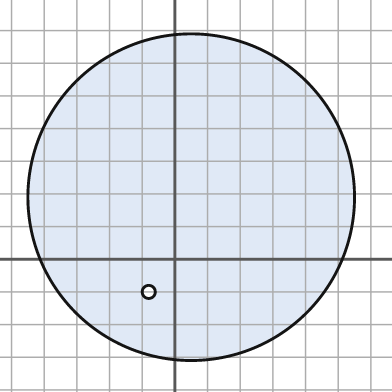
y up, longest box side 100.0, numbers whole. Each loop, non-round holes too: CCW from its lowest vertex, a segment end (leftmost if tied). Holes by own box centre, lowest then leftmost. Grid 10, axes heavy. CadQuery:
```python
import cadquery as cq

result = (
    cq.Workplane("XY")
    .moveTo(5.0, 19.0)
    .circle(50.0)
    .moveTo(-8.0, -10.0)
    .circle(2.0)
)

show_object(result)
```